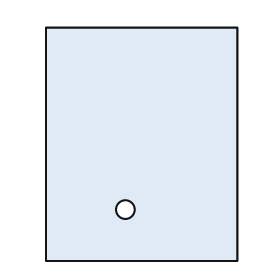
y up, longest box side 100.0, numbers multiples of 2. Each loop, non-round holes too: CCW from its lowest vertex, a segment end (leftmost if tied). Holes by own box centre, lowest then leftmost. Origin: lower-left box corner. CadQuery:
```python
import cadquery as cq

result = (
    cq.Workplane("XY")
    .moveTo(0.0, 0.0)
    .lineTo(82.0, 0.0)
    .lineTo(82.0, 100.0)
    .lineTo(0.0, 100.0)
    .close()
    .moveTo(34.0, 22.0)
    .circle(4.0)
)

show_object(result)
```